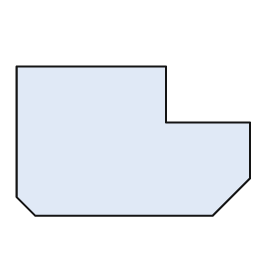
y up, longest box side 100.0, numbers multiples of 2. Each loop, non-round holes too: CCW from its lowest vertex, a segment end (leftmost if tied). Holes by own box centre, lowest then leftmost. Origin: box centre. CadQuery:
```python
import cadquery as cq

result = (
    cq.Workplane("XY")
    .moveTo(-42.0, -32.0)
    .lineTo(34.0, -32.0)
    .lineTo(50.0, -16.0)
    .lineTo(50.0, 8.0)
    .lineTo(14.0, 8.0)
    .lineTo(14.0, 32.0)
    .lineTo(-50.0, 32.0)
    .lineTo(-50.0, -24.0)
    .close()
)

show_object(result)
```